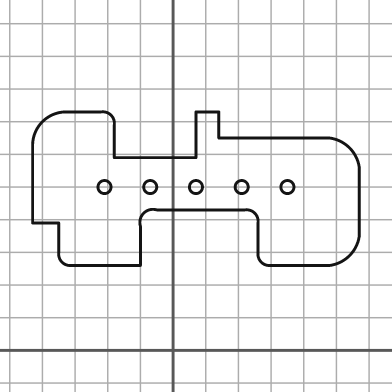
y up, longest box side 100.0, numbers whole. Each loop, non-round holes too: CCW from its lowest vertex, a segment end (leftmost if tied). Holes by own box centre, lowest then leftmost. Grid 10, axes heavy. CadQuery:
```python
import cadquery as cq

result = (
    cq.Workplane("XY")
    .moveTo(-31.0, 26.0)
    .lineTo(-10.0, 26.0)
    .lineTo(-10.0, 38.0)
    .threePointArc((-9.0, 42.0), (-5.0, 43.0))
    .lineTo(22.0, 43.0)
    .threePointArc((25.0, 42.0), (26.0, 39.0))
    .lineTo(26.0, 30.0)
    .threePointArc((27.0, 27.0), (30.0, 26.0))
    .lineTo(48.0, 26.0)
    .threePointArc((54.0, 29.0), (57.0, 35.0))
    .lineTo(57.0, 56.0)
    .threePointArc((54.0, 62.0), (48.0, 65.0))
    .lineTo(14.0, 65.0)
    .lineTo(14.0, 73.0)
    .lineTo(7.0, 73.0)
    .lineTo(7.0, 59.0)
    .lineTo(-18.0, 59.0)
    .lineTo(-18.0, 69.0)
    .threePointArc((-19.0, 72.0), (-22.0, 73.0))
    .lineTo(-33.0, 73.0)
    .threePointArc((-40.0, 70.0), (-43.0, 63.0))
    .lineTo(-43.0, 39.0)
    .lineTo(-35.0, 39.0)
    .lineTo(-35.0, 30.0)
    .threePointArc((-34.0, 27.0), (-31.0, 26.0))
    .close()
    .moveTo(-21.0, 50.0)
    .circle(2.0)
    .moveTo(-7.0, 50.0)
    .circle(2.0)
    .moveTo(7.0, 50.0)
    .circle(2.0)
    .moveTo(21.0, 50.0)
    .circle(2.0)
    .moveTo(35.0, 50.0)
    .circle(2.0)
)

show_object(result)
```